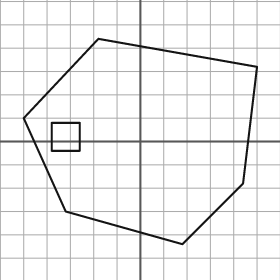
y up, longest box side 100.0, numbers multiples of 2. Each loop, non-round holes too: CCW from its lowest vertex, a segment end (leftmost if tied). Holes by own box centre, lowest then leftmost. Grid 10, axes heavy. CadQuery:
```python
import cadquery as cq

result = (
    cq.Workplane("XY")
    .moveTo(18.0, -44.0)
    .lineTo(44.0, -18.0)
    .lineTo(50.0, 32.0)
    .lineTo(-18.0, 44.0)
    .lineTo(-50.0, 10.0)
    .lineTo(-32.0, -30.0)
    .close()
    .moveTo(-38.0, -4.0)
    .lineTo(-26.0, -4.0)
    .lineTo(-26.0, 8.0)
    .lineTo(-38.0, 8.0)
    .close()
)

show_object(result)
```